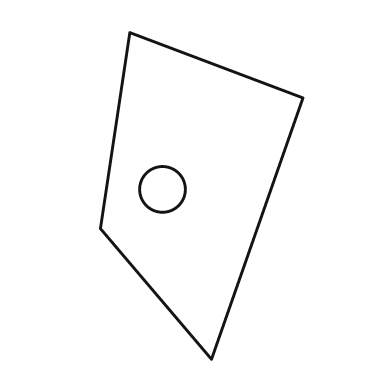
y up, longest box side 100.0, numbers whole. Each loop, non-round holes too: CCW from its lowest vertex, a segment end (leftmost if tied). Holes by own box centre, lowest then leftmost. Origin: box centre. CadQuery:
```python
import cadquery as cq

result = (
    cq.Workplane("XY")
    .moveTo(3.0, -50.0)
    .lineTo(31.0, 30.0)
    .lineTo(-22.0, 50.0)
    .lineTo(-31.0, -10.0)
    .close()
    .moveTo(-12.0, 2.0)
    .circle(7.0)
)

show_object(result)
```